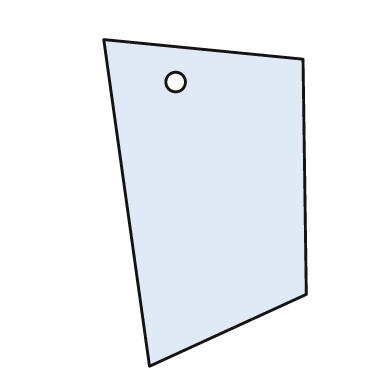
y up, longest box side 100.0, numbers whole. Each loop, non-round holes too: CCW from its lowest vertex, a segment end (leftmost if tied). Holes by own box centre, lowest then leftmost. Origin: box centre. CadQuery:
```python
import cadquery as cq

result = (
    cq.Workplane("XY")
    .moveTo(-17.0, -50.0)
    .lineTo(31.0, -28.0)
    .lineTo(30.0, 44.0)
    .lineTo(-31.0, 50.0)
    .close()
    .moveTo(-9.0, 37.0)
    .circle(3.0)
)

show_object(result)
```